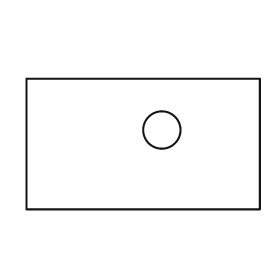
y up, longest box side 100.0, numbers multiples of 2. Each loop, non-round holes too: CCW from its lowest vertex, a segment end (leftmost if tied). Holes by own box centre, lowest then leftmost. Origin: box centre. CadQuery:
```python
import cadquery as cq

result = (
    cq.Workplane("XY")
    .moveTo(-50.0, -28.0)
    .lineTo(50.0, -28.0)
    .lineTo(50.0, 28.0)
    .lineTo(-50.0, 28.0)
    .close()
    .moveTo(8.0, 6.0)
    .circle(8.0)
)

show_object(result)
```